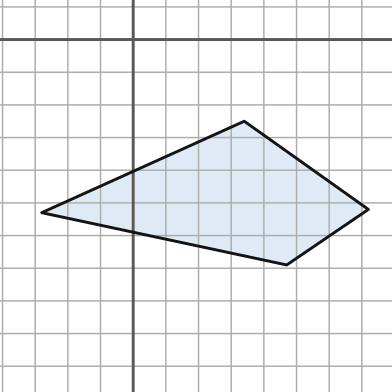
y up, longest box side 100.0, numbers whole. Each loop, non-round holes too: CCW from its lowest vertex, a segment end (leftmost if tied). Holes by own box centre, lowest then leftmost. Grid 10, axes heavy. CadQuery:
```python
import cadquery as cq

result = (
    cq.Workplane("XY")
    .moveTo(47.0, -69.0)
    .lineTo(72.0, -52.0)
    .lineTo(34.0, -25.0)
    .lineTo(-28.0, -53.0)
    .close()
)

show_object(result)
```